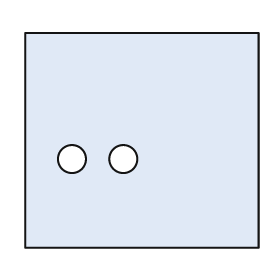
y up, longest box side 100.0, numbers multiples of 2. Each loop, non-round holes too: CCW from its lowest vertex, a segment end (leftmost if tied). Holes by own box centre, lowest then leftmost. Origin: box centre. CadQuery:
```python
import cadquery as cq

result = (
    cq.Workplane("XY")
    .moveTo(-50.0, -46.0)
    .lineTo(50.0, -46.0)
    .lineTo(50.0, 46.0)
    .lineTo(-50.0, 46.0)
    .close()
    .moveTo(-30.0, -8.0)
    .circle(6.0)
    .moveTo(-8.0, -8.0)
    .circle(6.0)
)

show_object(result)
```